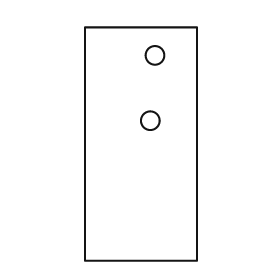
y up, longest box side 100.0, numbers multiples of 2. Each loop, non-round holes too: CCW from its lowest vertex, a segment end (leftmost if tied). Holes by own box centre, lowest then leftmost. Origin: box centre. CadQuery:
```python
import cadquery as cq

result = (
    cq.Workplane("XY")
    .moveTo(-24.0, -50.0)
    .lineTo(24.0, -50.0)
    .lineTo(24.0, 50.0)
    .lineTo(-24.0, 50.0)
    .close()
    .moveTo(4.0, 10.0)
    .circle(4.0)
    .moveTo(6.0, 38.0)
    .circle(4.0)
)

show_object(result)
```